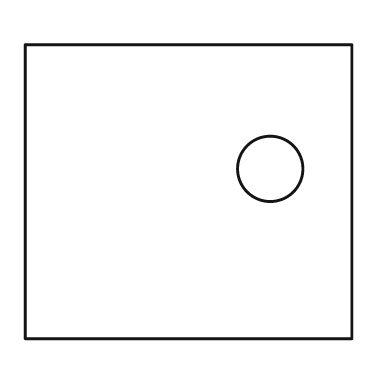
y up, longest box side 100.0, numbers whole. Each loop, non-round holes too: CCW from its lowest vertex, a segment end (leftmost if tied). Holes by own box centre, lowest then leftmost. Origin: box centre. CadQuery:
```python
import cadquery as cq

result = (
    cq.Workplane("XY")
    .moveTo(-50.0, -45.0)
    .lineTo(50.0, -45.0)
    .lineTo(50.0, 45.0)
    .lineTo(-50.0, 45.0)
    .close()
    .moveTo(25.0, 7.0)
    .circle(10.0)
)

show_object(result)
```